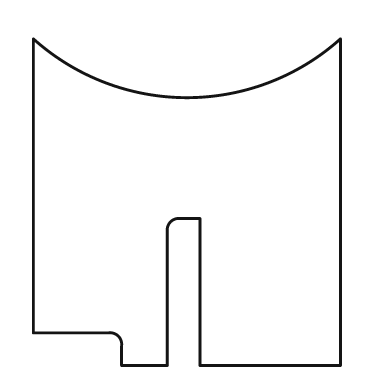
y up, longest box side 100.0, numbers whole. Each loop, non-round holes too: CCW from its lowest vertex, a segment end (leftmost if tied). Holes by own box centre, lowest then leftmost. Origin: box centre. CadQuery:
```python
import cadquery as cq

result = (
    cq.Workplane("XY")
    .moveTo(-20.0, -50.0)
    .lineTo(-6.0, -50.0)
    .lineTo(-6.0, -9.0)
    .threePointArc((-5.0, -6.0), (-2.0, -5.0))
    .lineTo(4.0, -5.0)
    .lineTo(4.0, -50.0)
    .lineTo(47.0, -50.0)
    .lineTo(47.0, 50.0)
    .threePointArc((0.0, 32.0), (-47.0, 50.0))
    .lineTo(-47.0, -40.0)
    .lineTo(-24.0, -40.0)
    .threePointArc((-21.0, -41.0), (-20.0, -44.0))
    .close()
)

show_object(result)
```